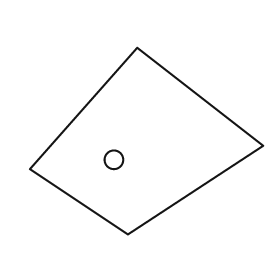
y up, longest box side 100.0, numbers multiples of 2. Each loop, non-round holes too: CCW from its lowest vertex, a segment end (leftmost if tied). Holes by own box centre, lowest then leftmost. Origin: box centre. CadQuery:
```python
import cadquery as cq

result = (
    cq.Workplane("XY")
    .moveTo(-8.0, -40.0)
    .lineTo(50.0, -2.0)
    .lineTo(-4.0, 40.0)
    .lineTo(-50.0, -12.0)
    .close()
    .moveTo(-14.0, -8.0)
    .circle(4.0)
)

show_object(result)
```